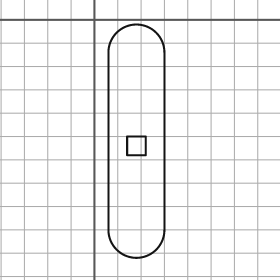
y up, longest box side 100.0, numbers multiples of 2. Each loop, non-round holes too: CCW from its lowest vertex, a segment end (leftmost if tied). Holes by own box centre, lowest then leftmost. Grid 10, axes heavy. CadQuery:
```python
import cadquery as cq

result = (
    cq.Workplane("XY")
    .moveTo(6.0, -90.0)
    .threePointArc((18.0, -102.0), (30.0, -90.0))
    .lineTo(30.0, -14.0)
    .threePointArc((18.0, -2.0), (6.0, -14.0))
    .close()
    .moveTo(14.0, -58.0)
    .lineTo(22.0, -58.0)
    .lineTo(22.0, -50.0)
    .lineTo(14.0, -50.0)
    .close()
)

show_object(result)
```